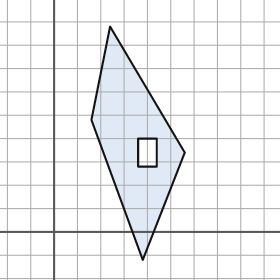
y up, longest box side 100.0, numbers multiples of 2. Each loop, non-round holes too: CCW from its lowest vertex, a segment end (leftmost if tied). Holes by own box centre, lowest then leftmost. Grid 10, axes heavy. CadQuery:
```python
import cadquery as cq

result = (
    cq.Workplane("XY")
    .moveTo(38.0, -12.0)
    .lineTo(56.0, 34.0)
    .lineTo(24.0, 88.0)
    .lineTo(16.0, 48.0)
    .close()
    .moveTo(36.0, 28.0)
    .lineTo(44.0, 28.0)
    .lineTo(44.0, 40.0)
    .lineTo(36.0, 40.0)
    .close()
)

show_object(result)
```